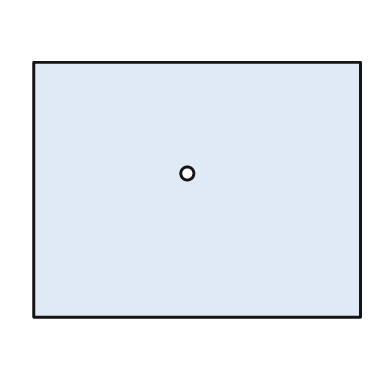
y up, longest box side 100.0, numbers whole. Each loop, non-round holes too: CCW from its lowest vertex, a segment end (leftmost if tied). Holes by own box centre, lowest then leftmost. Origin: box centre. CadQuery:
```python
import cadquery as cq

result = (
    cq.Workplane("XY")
    .moveTo(-50.0, -39.0)
    .lineTo(50.0, -39.0)
    .lineTo(50.0, 39.0)
    .lineTo(-50.0, 39.0)
    .close()
    .moveTo(-3.0, 5.0)
    .circle(2.0)
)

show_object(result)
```